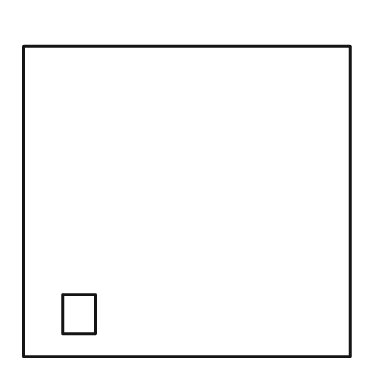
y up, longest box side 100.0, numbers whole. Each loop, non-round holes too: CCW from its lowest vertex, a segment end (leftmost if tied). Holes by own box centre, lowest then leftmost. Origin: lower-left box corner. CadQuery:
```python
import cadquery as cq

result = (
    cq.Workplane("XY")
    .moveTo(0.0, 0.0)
    .lineTo(100.0, 0.0)
    .lineTo(100.0, 95.0)
    .lineTo(0.0, 95.0)
    .close()
    .moveTo(12.0, 7.0)
    .lineTo(22.0, 7.0)
    .lineTo(22.0, 19.0)
    .lineTo(12.0, 19.0)
    .close()
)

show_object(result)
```